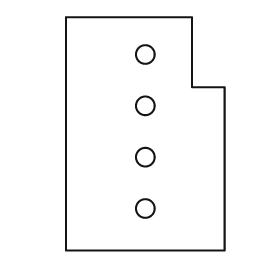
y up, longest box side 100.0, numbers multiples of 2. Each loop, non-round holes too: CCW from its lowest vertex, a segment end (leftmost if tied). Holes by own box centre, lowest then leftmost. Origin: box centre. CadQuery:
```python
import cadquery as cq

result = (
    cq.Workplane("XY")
    .moveTo(-34.0, -50.0)
    .lineTo(34.0, -50.0)
    .lineTo(34.0, 20.0)
    .lineTo(20.0, 20.0)
    .lineTo(20.0, 50.0)
    .lineTo(-34.0, 50.0)
    .close()
    .moveTo(0.0, -32.0)
    .circle(4.0)
    .moveTo(0.0, -10.0)
    .circle(4.0)
    .moveTo(0.0, 12.0)
    .circle(4.0)
    .moveTo(0.0, 34.0)
    .circle(4.0)
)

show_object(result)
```